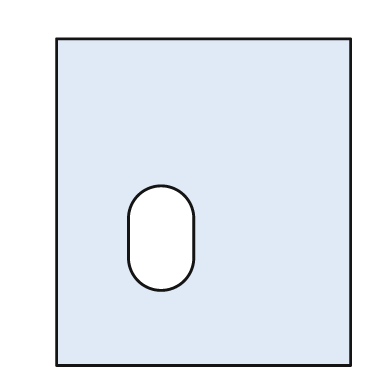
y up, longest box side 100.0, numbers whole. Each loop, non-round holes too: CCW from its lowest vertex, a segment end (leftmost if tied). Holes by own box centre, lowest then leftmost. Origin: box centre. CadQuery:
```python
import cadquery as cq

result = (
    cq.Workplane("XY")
    .moveTo(-45.0, -50.0)
    .lineTo(45.0, -50.0)
    .lineTo(45.0, 50.0)
    .lineTo(-45.0, 50.0)
    .close()
    .moveTo(-23.0, -17.0)
    .threePointArc((-13.0, -27.0), (-3.0, -17.0))
    .lineTo(-3.0, -5.0)
    .threePointArc((-13.0, 5.0), (-23.0, -5.0))
    .close()
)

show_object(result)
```